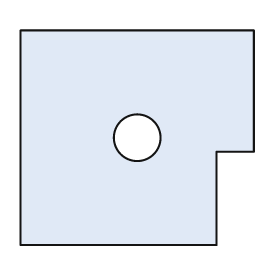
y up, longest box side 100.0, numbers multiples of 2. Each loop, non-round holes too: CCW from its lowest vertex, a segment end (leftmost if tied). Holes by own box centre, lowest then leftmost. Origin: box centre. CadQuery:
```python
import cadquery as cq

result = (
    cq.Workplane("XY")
    .moveTo(-50.0, -46.0)
    .lineTo(34.0, -46.0)
    .lineTo(34.0, -6.0)
    .lineTo(50.0, -6.0)
    .lineTo(50.0, 46.0)
    .lineTo(-50.0, 46.0)
    .close()
    .moveTo(0.0, 0.0)
    .circle(10.0)
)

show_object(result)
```